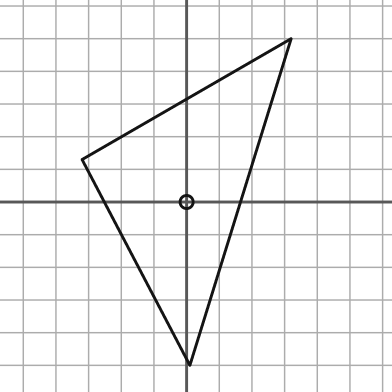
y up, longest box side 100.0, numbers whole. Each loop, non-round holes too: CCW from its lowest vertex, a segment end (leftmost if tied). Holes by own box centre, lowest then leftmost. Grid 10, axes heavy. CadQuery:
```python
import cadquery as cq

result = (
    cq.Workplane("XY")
    .moveTo(1.0, -50.0)
    .lineTo(32.0, 50.0)
    .lineTo(-32.0, 13.0)
    .close()
    .moveTo(0.0, 0.0)
    .circle(2.0)
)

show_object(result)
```